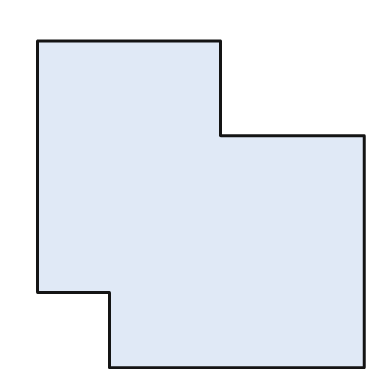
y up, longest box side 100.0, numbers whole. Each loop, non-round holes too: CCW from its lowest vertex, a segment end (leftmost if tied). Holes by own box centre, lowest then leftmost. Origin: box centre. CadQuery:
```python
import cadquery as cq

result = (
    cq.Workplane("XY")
    .moveTo(-28.0, -50.0)
    .lineTo(50.0, -50.0)
    .lineTo(50.0, 21.0)
    .lineTo(6.0, 21.0)
    .lineTo(6.0, 50.0)
    .lineTo(-50.0, 50.0)
    .lineTo(-50.0, -27.0)
    .lineTo(-28.0, -27.0)
    .close()
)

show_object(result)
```